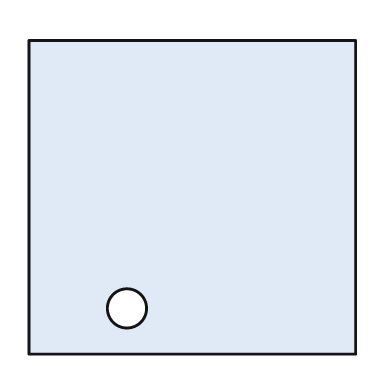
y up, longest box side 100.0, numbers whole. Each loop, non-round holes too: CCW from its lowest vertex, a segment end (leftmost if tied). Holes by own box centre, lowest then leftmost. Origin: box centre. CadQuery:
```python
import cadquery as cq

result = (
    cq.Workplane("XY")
    .moveTo(-50.0, -48.0)
    .lineTo(50.0, -48.0)
    .lineTo(50.0, 48.0)
    .lineTo(-50.0, 48.0)
    .close()
    .moveTo(-20.0, -34.0)
    .circle(6.0)
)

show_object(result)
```